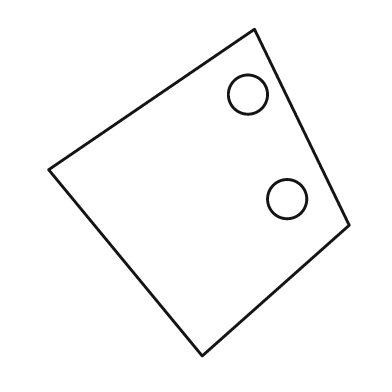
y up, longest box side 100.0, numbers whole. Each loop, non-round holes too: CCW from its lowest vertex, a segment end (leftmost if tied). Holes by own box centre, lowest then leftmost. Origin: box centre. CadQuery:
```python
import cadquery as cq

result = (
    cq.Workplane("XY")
    .moveTo(1.0, -50.0)
    .lineTo(46.0, -10.0)
    .lineTo(17.0, 50.0)
    .lineTo(-46.0, 7.0)
    .close()
    .moveTo(27.0, -2.0)
    .circle(6.0)
    .moveTo(15.0, 30.0)
    .circle(6.0)
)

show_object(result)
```